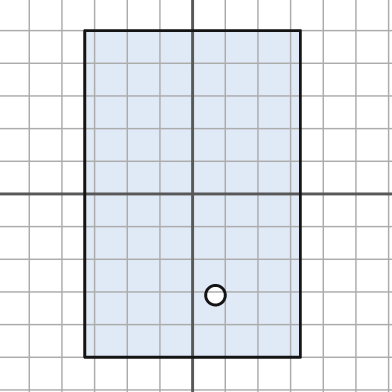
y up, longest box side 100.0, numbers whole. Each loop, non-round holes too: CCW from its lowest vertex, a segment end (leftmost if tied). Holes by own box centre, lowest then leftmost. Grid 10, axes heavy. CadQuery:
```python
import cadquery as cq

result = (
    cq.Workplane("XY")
    .moveTo(-33.0, -50.0)
    .lineTo(33.0, -50.0)
    .lineTo(33.0, 50.0)
    .lineTo(-33.0, 50.0)
    .close()
    .moveTo(7.0, -31.0)
    .circle(3.0)
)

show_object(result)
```